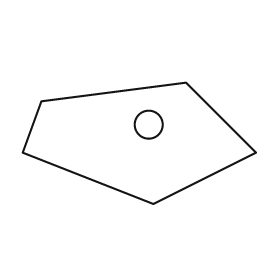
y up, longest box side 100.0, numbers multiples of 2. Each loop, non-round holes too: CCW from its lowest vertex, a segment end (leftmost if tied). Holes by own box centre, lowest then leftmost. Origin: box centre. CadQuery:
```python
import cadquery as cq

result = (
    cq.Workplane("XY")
    .moveTo(6.0, -26.0)
    .lineTo(50.0, -4.0)
    .lineTo(20.0, 26.0)
    .lineTo(-42.0, 18.0)
    .lineTo(-50.0, -4.0)
    .close()
    .moveTo(4.0, 8.0)
    .circle(6.0)
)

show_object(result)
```